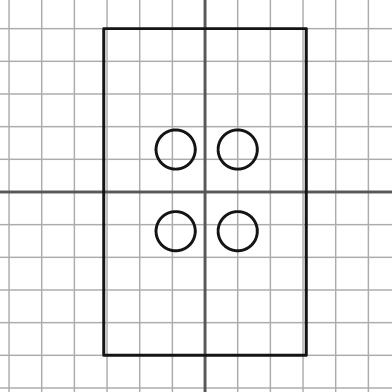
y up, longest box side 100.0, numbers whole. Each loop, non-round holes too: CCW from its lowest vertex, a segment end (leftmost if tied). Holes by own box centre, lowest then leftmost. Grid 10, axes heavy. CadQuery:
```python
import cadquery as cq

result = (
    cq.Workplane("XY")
    .moveTo(-31.0, -50.0)
    .lineTo(31.0, -50.0)
    .lineTo(31.0, 50.0)
    .lineTo(-31.0, 50.0)
    .close()
    .moveTo(-9.0, -12.0)
    .circle(6.0)
    .moveTo(10.0, -12.0)
    .circle(6.0)
    .moveTo(-9.0, 13.0)
    .circle(6.0)
    .moveTo(10.0, 13.0)
    .circle(6.0)
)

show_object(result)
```